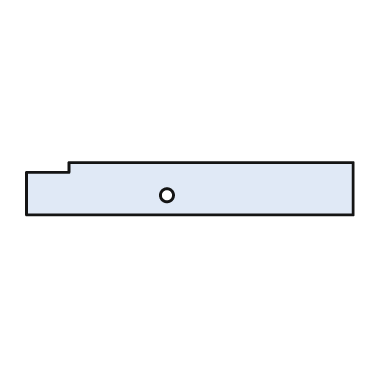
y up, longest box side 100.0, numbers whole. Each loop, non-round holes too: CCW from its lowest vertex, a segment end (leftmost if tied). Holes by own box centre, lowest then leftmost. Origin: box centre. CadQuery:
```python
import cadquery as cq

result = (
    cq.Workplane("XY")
    .moveTo(-50.0, -8.0)
    .lineTo(50.0, -8.0)
    .lineTo(50.0, 8.0)
    .lineTo(-37.0, 8.0)
    .lineTo(-37.0, 5.0)
    .lineTo(-50.0, 5.0)
    .close()
    .moveTo(-7.0, -2.0)
    .circle(2.0)
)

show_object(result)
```